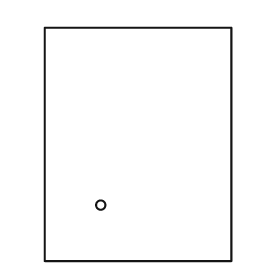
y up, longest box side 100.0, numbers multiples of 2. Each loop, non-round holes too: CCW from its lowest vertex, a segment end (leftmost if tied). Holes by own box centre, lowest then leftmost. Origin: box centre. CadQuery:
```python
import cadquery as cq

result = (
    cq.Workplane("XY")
    .moveTo(-40.0, -50.0)
    .lineTo(40.0, -50.0)
    .lineTo(40.0, 50.0)
    .lineTo(-40.0, 50.0)
    .close()
    .moveTo(-16.0, -26.0)
    .circle(2.0)
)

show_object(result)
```